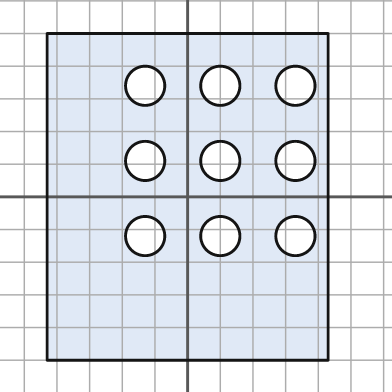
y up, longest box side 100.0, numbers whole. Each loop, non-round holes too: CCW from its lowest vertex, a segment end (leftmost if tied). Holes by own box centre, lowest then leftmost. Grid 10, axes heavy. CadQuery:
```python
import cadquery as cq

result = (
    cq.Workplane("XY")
    .moveTo(-43.0, -50.0)
    .lineTo(43.0, -50.0)
    .lineTo(43.0, 50.0)
    .lineTo(-43.0, 50.0)
    .close()
    .moveTo(-13.0, -12.0)
    .circle(6.0)
    .moveTo(10.0, -12.0)
    .circle(6.0)
    .moveTo(33.0, -12.0)
    .circle(6.0)
    .moveTo(-13.0, 11.0)
    .circle(6.0)
    .moveTo(10.0, 11.0)
    .circle(6.0)
    .moveTo(33.0, 11.0)
    .circle(6.0)
    .moveTo(-13.0, 34.0)
    .circle(6.0)
    .moveTo(10.0, 34.0)
    .circle(6.0)
    .moveTo(33.0, 34.0)
    .circle(6.0)
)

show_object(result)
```